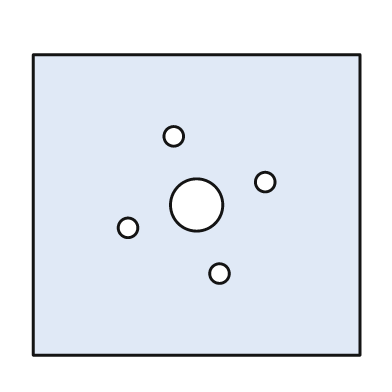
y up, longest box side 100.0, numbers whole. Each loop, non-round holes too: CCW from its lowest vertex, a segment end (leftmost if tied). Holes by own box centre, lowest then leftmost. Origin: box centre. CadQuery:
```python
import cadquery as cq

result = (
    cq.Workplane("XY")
    .moveTo(-50.0, -46.0)
    .lineTo(50.0, -46.0)
    .lineTo(50.0, 46.0)
    .lineTo(-50.0, 46.0)
    .close()
    .moveTo(7.0, -21.0)
    .circle(3.0)
    .moveTo(-21.0, -7.0)
    .circle(3.0)
    .moveTo(0.0, 0.0)
    .circle(8.0)
    .moveTo(21.0, 7.0)
    .circle(3.0)
    .moveTo(-7.0, 21.0)
    .circle(3.0)
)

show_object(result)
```